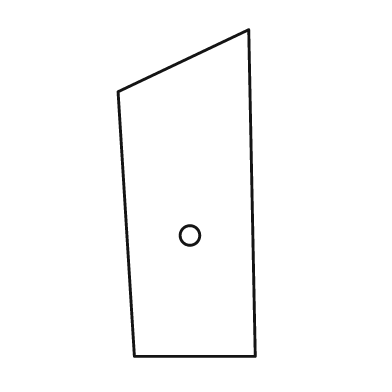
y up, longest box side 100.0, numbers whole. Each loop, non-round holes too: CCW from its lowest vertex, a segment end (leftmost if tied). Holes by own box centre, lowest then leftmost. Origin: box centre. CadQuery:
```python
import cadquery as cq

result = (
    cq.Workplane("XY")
    .moveTo(-16.0, -50.0)
    .lineTo(21.0, -50.0)
    .lineTo(19.0, 50.0)
    .lineTo(-21.0, 31.0)
    .close()
    .moveTo(1.0, -13.0)
    .circle(3.0)
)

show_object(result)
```